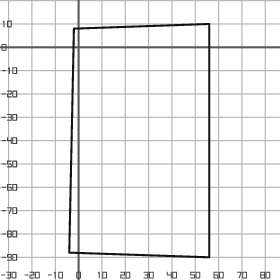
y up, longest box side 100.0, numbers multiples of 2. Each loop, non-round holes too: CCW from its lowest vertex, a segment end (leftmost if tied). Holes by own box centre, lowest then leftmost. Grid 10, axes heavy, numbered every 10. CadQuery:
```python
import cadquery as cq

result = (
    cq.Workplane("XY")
    .moveTo(56.0, -90.0)
    .lineTo(56.0, 10.0)
    .lineTo(-2.0, 8.0)
    .lineTo(-4.0, -88.0)
    .close()
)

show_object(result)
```